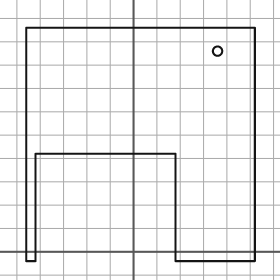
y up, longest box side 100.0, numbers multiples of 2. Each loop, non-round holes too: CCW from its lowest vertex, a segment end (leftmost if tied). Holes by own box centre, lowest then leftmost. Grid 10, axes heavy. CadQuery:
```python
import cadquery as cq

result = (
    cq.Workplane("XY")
    .moveTo(-46.0, -4.0)
    .lineTo(-42.0, -4.0)
    .lineTo(-42.0, 42.0)
    .lineTo(18.0, 42.0)
    .lineTo(18.0, -4.0)
    .lineTo(52.0, -4.0)
    .lineTo(52.0, 96.0)
    .lineTo(-46.0, 96.0)
    .close()
    .moveTo(36.0, 86.0)
    .circle(2.0)
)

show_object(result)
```